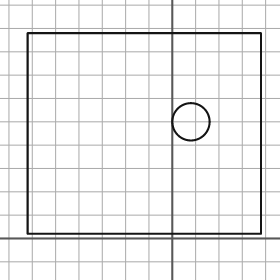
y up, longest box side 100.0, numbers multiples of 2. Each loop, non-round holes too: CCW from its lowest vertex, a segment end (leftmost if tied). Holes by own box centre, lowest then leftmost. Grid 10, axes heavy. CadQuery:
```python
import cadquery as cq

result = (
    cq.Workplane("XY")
    .moveTo(-62.0, 2.0)
    .lineTo(38.0, 2.0)
    .lineTo(38.0, 88.0)
    .lineTo(-62.0, 88.0)
    .close()
    .moveTo(8.0, 50.0)
    .circle(8.0)
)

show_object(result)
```